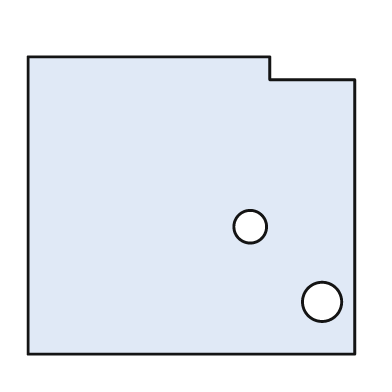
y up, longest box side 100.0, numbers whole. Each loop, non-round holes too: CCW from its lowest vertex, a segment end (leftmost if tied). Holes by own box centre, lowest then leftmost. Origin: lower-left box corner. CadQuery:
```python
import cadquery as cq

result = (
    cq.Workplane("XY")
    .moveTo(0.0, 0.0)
    .lineTo(100.0, 0.0)
    .lineTo(100.0, 84.0)
    .lineTo(74.0, 84.0)
    .lineTo(74.0, 91.0)
    .lineTo(0.0, 91.0)
    .close()
    .moveTo(90.0, 16.0)
    .circle(6.0)
    .moveTo(68.0, 39.0)
    .circle(5.0)
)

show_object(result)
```